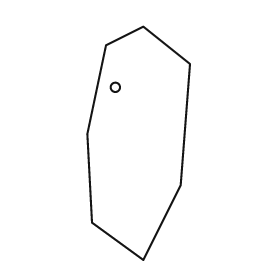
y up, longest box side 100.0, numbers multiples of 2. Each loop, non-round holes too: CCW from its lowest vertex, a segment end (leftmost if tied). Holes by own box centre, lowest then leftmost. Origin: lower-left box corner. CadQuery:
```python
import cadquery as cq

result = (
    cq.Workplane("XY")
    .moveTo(24.0, 0.0)
    .lineTo(40.0, 32.0)
    .lineTo(44.0, 84.0)
    .lineTo(24.0, 100.0)
    .lineTo(8.0, 92.0)
    .lineTo(0.0, 54.0)
    .lineTo(2.0, 16.0)
    .close()
    .moveTo(12.0, 74.0)
    .circle(2.0)
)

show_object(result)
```